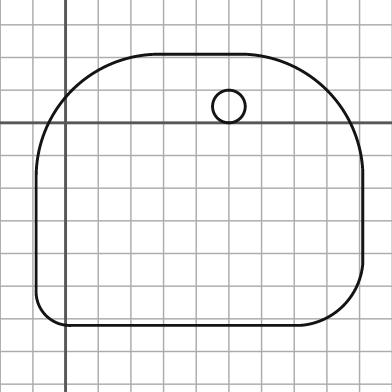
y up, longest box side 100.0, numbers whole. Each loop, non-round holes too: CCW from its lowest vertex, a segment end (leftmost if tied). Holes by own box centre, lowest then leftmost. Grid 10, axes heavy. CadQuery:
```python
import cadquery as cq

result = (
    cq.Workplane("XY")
    .moveTo(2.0, -62.0)
    .lineTo(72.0, -62.0)
    .threePointArc((85.0, -56.0), (91.0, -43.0))
    .lineTo(91.0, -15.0)
    .threePointArc((80.0, 10.0), (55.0, 21.0))
    .lineTo(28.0, 21.0)
    .threePointArc((2.0, 10.0), (-9.0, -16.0))
    .lineTo(-9.0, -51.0)
    .threePointArc((-6.0, -59.0), (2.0, -62.0))
    .close()
    .moveTo(50.0, 5.0)
    .circle(5.0)
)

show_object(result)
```